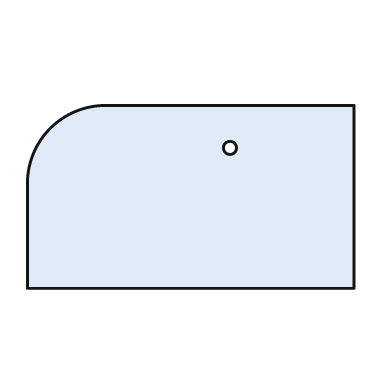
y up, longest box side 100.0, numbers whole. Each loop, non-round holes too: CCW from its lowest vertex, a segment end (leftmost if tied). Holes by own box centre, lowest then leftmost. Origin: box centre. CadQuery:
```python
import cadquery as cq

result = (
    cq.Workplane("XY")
    .moveTo(-50.0, -28.0)
    .lineTo(50.0, -28.0)
    .lineTo(50.0, 28.0)
    .lineTo(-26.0, 28.0)
    .threePointArc((-43.0, 21.0), (-50.0, 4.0))
    .close()
    .moveTo(12.0, 15.0)
    .circle(2.0)
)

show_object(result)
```